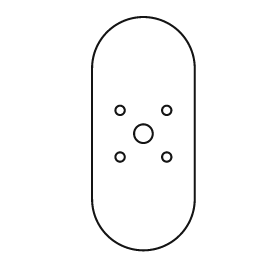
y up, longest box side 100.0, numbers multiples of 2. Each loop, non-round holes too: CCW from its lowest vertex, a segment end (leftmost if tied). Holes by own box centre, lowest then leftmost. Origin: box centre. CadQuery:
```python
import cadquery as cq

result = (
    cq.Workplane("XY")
    .moveTo(-22.0, -28.0)
    .threePointArc((0.0, -50.0), (22.0, -28.0))
    .lineTo(22.0, 28.0)
    .threePointArc((0.0, 50.0), (-22.0, 28.0))
    .close()
    .moveTo(-10.0, -10.0)
    .circle(2.0)
    .moveTo(10.0, -10.0)
    .circle(2.0)
    .moveTo(0.0, 0.0)
    .circle(4.0)
    .moveTo(-10.0, 10.0)
    .circle(2.0)
    .moveTo(10.0, 10.0)
    .circle(2.0)
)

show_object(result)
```